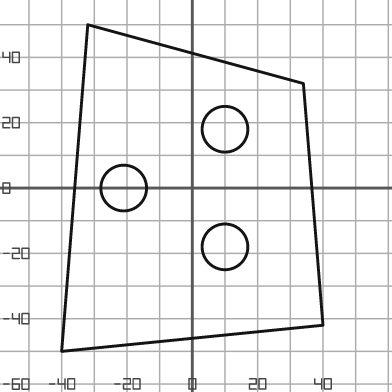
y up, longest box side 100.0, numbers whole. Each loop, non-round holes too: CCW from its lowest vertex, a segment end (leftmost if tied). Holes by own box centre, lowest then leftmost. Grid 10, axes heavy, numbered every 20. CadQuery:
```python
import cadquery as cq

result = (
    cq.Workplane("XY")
    .moveTo(-40.0, -50.0)
    .lineTo(40.0, -42.0)
    .lineTo(34.0, 32.0)
    .lineTo(-32.0, 50.0)
    .close()
    .moveTo(10.0, -18.0)
    .circle(7.0)
    .moveTo(-21.0, 0.0)
    .circle(7.0)
    .moveTo(10.0, 18.0)
    .circle(7.0)
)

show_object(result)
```